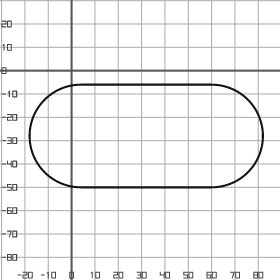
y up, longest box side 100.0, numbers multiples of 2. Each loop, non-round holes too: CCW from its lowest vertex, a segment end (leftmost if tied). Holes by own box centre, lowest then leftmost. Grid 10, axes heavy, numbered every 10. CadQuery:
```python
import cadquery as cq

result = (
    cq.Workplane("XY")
    .moveTo(4.0, -50.0)
    .lineTo(60.0, -50.0)
    .threePointArc((82.0, -28.0), (60.0, -6.0))
    .lineTo(4.0, -6.0)
    .threePointArc((-18.0, -28.0), (4.0, -50.0))
    .close()
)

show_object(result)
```